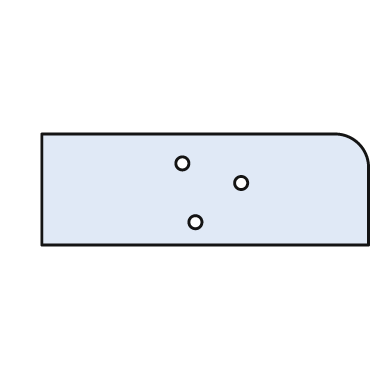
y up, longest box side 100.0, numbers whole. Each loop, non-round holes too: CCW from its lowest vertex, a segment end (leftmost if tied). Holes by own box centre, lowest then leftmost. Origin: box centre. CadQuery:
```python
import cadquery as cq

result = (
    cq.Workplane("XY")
    .moveTo(-50.0, -17.0)
    .lineTo(50.0, -17.0)
    .lineTo(50.0, 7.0)
    .threePointArc((47.0, 14.0), (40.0, 17.0))
    .lineTo(-50.0, 17.0)
    .close()
    .moveTo(-3.0, -10.0)
    .circle(2.0)
    .moveTo(11.0, 2.0)
    .circle(2.0)
    .moveTo(-7.0, 8.0)
    .circle(2.0)
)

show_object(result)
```